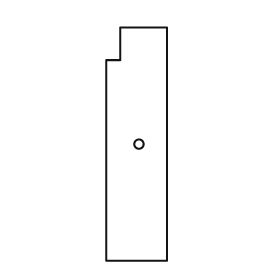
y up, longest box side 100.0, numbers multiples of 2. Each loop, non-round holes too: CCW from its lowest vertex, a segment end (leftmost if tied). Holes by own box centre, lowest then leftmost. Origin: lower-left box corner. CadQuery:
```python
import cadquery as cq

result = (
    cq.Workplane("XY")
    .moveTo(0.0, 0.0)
    .lineTo(26.0, 0.0)
    .lineTo(26.0, 100.0)
    .lineTo(6.0, 100.0)
    .lineTo(6.0, 86.0)
    .lineTo(0.0, 86.0)
    .close()
    .moveTo(14.0, 50.0)
    .circle(2.0)
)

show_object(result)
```